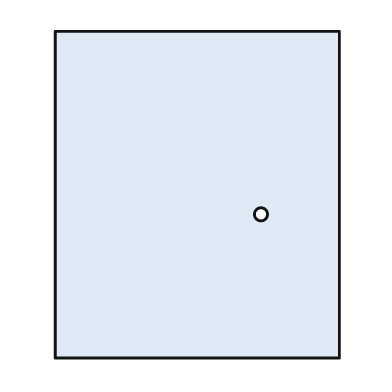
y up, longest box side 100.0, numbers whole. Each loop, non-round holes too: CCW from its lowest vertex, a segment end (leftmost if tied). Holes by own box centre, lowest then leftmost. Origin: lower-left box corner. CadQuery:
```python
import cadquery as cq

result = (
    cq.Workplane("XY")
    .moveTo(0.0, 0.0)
    .lineTo(87.0, 0.0)
    .lineTo(87.0, 100.0)
    .lineTo(0.0, 100.0)
    .close()
    .moveTo(63.0, 44.0)
    .circle(2.0)
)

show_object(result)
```